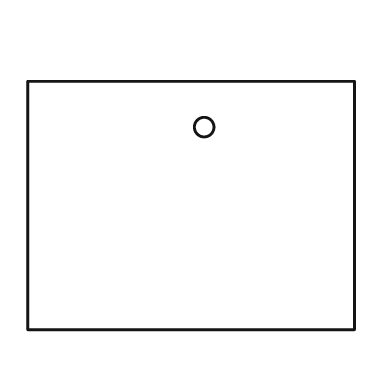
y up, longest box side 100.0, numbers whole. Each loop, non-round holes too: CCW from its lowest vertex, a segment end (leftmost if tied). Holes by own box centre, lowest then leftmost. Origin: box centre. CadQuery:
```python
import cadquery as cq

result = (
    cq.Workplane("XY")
    .moveTo(-50.0, -38.0)
    .lineTo(50.0, -38.0)
    .lineTo(50.0, 38.0)
    .lineTo(-50.0, 38.0)
    .close()
    .moveTo(4.0, 24.0)
    .circle(3.0)
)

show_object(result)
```